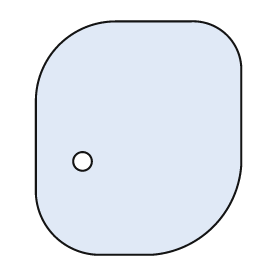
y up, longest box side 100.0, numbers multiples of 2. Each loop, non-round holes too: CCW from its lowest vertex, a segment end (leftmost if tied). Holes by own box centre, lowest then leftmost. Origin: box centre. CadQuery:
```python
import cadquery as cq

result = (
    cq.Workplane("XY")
    .moveTo(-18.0, -50.0)
    .lineTo(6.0, -50.0)
    .threePointArc((32.0, -38.0), (44.0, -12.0))
    .lineTo(44.0, 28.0)
    .threePointArc((38.0, 44.0), (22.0, 50.0))
    .lineTo(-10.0, 50.0)
    .threePointArc((-34.0, 40.0), (-44.0, 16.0))
    .lineTo(-44.0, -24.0)
    .threePointArc((-36.0, -42.0), (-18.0, -50.0))
    .close()
    .moveTo(-24.0, -10.0)
    .circle(4.0)
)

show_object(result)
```